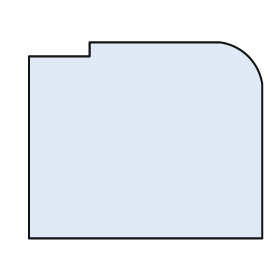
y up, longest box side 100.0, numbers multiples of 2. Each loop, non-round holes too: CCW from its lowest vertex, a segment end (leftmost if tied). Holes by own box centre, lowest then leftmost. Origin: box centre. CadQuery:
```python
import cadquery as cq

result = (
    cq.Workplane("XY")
    .moveTo(-50.0, -42.0)
    .lineTo(50.0, -42.0)
    .lineTo(50.0, 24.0)
    .threePointArc((44.0, 36.0), (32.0, 42.0))
    .lineTo(-24.0, 42.0)
    .lineTo(-24.0, 36.0)
    .lineTo(-50.0, 36.0)
    .close()
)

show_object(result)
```